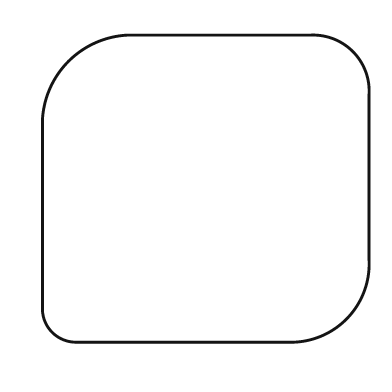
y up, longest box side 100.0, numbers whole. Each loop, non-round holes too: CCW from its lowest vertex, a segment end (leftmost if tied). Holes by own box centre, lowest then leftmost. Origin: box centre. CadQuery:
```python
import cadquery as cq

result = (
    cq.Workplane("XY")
    .moveTo(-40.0, -47.0)
    .lineTo(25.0, -47.0)
    .threePointArc((43.0, -40.0), (50.0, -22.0))
    .lineTo(50.0, 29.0)
    .threePointArc((45.0, 42.0), (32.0, 47.0))
    .lineTo(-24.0, 47.0)
    .threePointArc((-42.0, 39.0), (-50.0, 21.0))
    .lineTo(-50.0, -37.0)
    .threePointArc((-47.0, -44.0), (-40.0, -47.0))
    .close()
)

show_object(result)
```